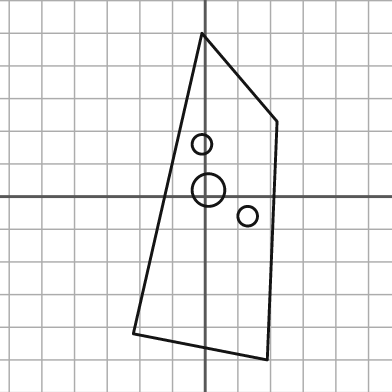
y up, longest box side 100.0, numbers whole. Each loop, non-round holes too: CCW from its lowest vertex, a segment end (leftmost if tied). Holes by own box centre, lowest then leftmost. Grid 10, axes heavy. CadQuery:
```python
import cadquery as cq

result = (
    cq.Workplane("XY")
    .moveTo(19.0, -50.0)
    .lineTo(22.0, 23.0)
    .lineTo(-1.0, 50.0)
    .lineTo(-22.0, -42.0)
    .close()
    .moveTo(13.0, -6.0)
    .circle(3.0)
    .moveTo(1.0, 2.0)
    .circle(5.0)
    .moveTo(-1.0, 16.0)
    .circle(3.0)
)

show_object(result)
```